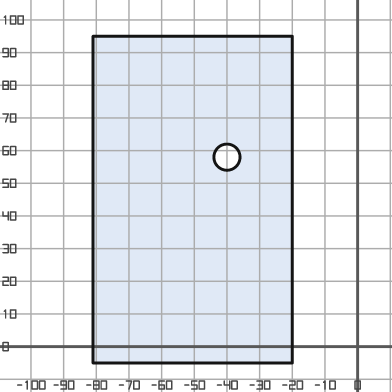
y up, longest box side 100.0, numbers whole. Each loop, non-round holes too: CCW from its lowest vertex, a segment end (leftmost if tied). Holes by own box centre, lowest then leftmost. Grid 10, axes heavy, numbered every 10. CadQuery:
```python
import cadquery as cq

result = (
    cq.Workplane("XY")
    .moveTo(-81.0, -5.0)
    .lineTo(-20.0, -5.0)
    .lineTo(-20.0, 95.0)
    .lineTo(-81.0, 95.0)
    .close()
    .moveTo(-40.0, 58.0)
    .circle(4.0)
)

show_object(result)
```